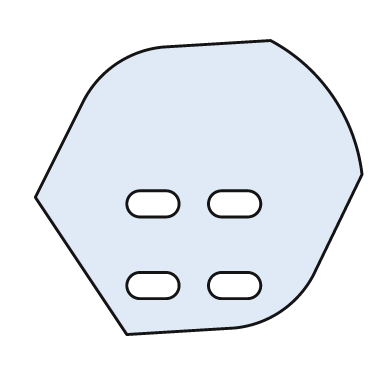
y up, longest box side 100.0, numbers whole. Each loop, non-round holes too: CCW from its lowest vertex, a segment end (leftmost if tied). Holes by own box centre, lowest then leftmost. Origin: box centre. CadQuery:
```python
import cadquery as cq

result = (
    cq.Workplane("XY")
    .moveTo(-22.0, -45.0)
    .lineTo(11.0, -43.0)
    .threePointArc((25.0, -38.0), (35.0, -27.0))
    .lineTo(50.0, 4.0)
    .threePointArc((41.0, 28.0), (22.0, 45.0))
    .lineTo(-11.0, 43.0)
    .threePointArc((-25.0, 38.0), (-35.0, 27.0))
    .lineTo(-50.0, -3.0)
    .close()
    .moveTo(-18.0, -34.0)
    .lineTo(-10.0, -34.0)
    .threePointArc((-6.0, -30.0), (-10.0, -26.0))
    .lineTo(-18.0, -26.0)
    .threePointArc((-22.0, -30.0), (-18.0, -34.0))
    .close()
    .moveTo(7.0, -34.0)
    .lineTo(15.0, -34.0)
    .threePointArc((19.0, -30.0), (15.0, -26.0))
    .lineTo(7.0, -26.0)
    .threePointArc((3.0, -30.0), (7.0, -34.0))
    .close()
    .moveTo(-18.0, -9.0)
    .lineTo(-10.0, -9.0)
    .threePointArc((-6.0, -5.0), (-10.0, -1.0))
    .lineTo(-18.0, -1.0)
    .threePointArc((-22.0, -5.0), (-18.0, -9.0))
    .close()
    .moveTo(7.0, -9.0)
    .lineTo(15.0, -9.0)
    .threePointArc((19.0, -5.0), (15.0, -1.0))
    .lineTo(7.0, -1.0)
    .threePointArc((3.0, -5.0), (7.0, -9.0))
    .close()
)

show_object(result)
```